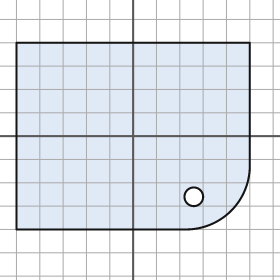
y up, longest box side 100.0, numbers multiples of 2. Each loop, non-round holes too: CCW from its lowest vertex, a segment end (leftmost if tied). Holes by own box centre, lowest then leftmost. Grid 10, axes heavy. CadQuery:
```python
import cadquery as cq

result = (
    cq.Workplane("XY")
    .moveTo(-50.0, -40.0)
    .lineTo(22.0, -40.0)
    .threePointArc((42.0, -32.0), (50.0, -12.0))
    .lineTo(50.0, 40.0)
    .lineTo(-50.0, 40.0)
    .close()
    .moveTo(26.0, -26.0)
    .circle(4.0)
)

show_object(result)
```